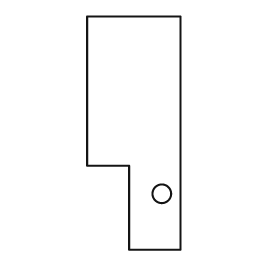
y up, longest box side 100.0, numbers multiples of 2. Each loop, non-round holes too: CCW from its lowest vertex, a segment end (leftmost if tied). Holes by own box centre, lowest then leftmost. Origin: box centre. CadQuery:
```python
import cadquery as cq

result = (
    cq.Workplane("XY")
    .moveTo(-2.0, -50.0)
    .lineTo(20.0, -50.0)
    .lineTo(20.0, 50.0)
    .lineTo(-20.0, 50.0)
    .lineTo(-20.0, -14.0)
    .lineTo(-2.0, -14.0)
    .close()
    .moveTo(12.0, -26.0)
    .circle(4.0)
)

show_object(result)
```